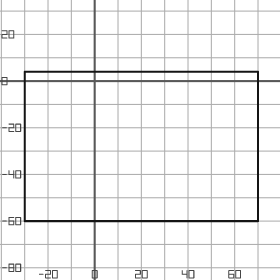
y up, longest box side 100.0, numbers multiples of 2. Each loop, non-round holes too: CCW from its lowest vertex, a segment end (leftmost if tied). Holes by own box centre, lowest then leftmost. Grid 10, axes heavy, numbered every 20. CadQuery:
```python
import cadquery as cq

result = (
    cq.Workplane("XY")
    .moveTo(-30.0, -60.0)
    .lineTo(70.0, -60.0)
    .lineTo(70.0, 4.0)
    .lineTo(-30.0, 4.0)
    .close()
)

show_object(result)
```